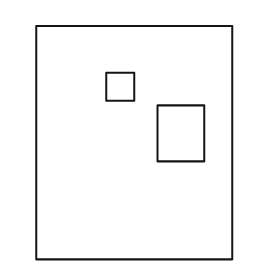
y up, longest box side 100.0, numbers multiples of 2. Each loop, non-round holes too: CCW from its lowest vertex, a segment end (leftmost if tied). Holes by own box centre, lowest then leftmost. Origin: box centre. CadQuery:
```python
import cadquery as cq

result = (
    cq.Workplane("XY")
    .moveTo(-42.0, -50.0)
    .lineTo(42.0, -50.0)
    .lineTo(42.0, 50.0)
    .lineTo(-42.0, 50.0)
    .close()
    .moveTo(10.0, -8.0)
    .lineTo(30.0, -8.0)
    .lineTo(30.0, 16.0)
    .lineTo(10.0, 16.0)
    .close()
    .moveTo(-12.0, 18.0)
    .lineTo(0.0, 18.0)
    .lineTo(0.0, 30.0)
    .lineTo(-12.0, 30.0)
    .close()
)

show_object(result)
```